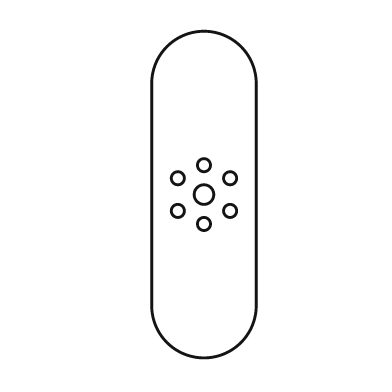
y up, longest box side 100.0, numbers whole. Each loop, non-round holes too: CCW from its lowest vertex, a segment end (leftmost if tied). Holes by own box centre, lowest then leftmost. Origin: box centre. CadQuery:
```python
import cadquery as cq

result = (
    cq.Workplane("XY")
    .moveTo(-16.0, -34.0)
    .threePointArc((0.0, -50.0), (16.0, -34.0))
    .lineTo(16.0, 34.0)
    .threePointArc((0.0, 50.0), (-16.0, 34.0))
    .close()
    .moveTo(0.0, -9.0)
    .circle(2.0)
    .moveTo(-8.0, -5.0)
    .circle(2.0)
    .moveTo(8.0, -5.0)
    .circle(2.0)
    .moveTo(0.0, 0.0)
    .circle(3.0)
    .moveTo(-8.0, 5.0)
    .circle(2.0)
    .moveTo(8.0, 5.0)
    .circle(2.0)
    .moveTo(0.0, 9.0)
    .circle(2.0)
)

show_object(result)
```